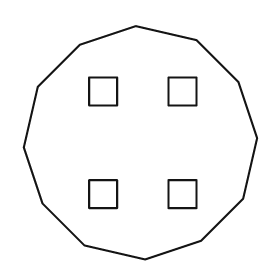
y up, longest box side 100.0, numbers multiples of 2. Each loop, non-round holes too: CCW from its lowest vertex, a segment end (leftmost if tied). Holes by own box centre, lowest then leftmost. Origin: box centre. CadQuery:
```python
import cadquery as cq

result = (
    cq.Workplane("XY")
    .moveTo(2.0, -50.0)
    .lineTo(26.0, -42.0)
    .lineTo(44.0, -24.0)
    .lineTo(50.0, 2.0)
    .lineTo(42.0, 26.0)
    .lineTo(24.0, 44.0)
    .lineTo(-2.0, 50.0)
    .lineTo(-26.0, 42.0)
    .lineTo(-44.0, 24.0)
    .lineTo(-50.0, -2.0)
    .lineTo(-42.0, -26.0)
    .lineTo(-24.0, -44.0)
    .close()
    .moveTo(-22.0, -28.0)
    .lineTo(-10.0, -28.0)
    .lineTo(-10.0, -16.0)
    .lineTo(-22.0, -16.0)
    .close()
    .moveTo(12.0, -28.0)
    .lineTo(24.0, -28.0)
    .lineTo(24.0, -16.0)
    .lineTo(12.0, -16.0)
    .close()
    .moveTo(-22.0, 16.0)
    .lineTo(-10.0, 16.0)
    .lineTo(-10.0, 28.0)
    .lineTo(-22.0, 28.0)
    .close()
    .moveTo(12.0, 16.0)
    .lineTo(24.0, 16.0)
    .lineTo(24.0, 28.0)
    .lineTo(12.0, 28.0)
    .close()
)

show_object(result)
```